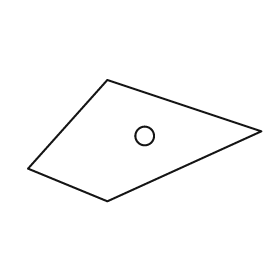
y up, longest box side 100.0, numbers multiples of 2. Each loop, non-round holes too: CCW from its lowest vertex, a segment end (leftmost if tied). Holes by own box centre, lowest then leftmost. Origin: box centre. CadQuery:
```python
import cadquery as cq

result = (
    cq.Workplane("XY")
    .moveTo(-16.0, -26.0)
    .lineTo(50.0, 4.0)
    .lineTo(-16.0, 26.0)
    .lineTo(-50.0, -12.0)
    .close()
    .moveTo(0.0, 2.0)
    .circle(4.0)
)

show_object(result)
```